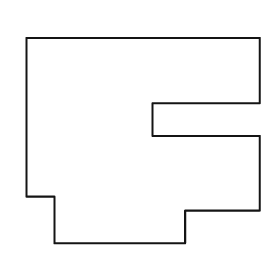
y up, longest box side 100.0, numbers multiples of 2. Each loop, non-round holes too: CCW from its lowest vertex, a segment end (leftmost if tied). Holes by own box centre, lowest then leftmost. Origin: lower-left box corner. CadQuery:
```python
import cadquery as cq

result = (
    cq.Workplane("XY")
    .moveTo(12.0, 0.0)
    .lineTo(68.0, 0.0)
    .lineTo(68.0, 14.0)
    .lineTo(100.0, 14.0)
    .lineTo(100.0, 46.0)
    .lineTo(54.0, 46.0)
    .lineTo(54.0, 60.0)
    .lineTo(100.0, 60.0)
    .lineTo(100.0, 88.0)
    .lineTo(0.0, 88.0)
    .lineTo(0.0, 20.0)
    .lineTo(12.0, 20.0)
    .close()
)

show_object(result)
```